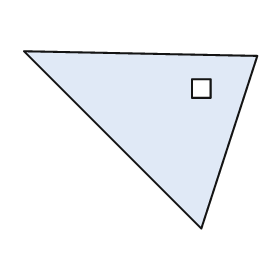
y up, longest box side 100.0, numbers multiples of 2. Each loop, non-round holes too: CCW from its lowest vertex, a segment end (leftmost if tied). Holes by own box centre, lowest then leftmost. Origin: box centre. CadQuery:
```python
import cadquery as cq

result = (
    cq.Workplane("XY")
    .moveTo(26.0, -38.0)
    .lineTo(50.0, 36.0)
    .lineTo(-50.0, 38.0)
    .close()
    .moveTo(22.0, 18.0)
    .lineTo(30.0, 18.0)
    .lineTo(30.0, 26.0)
    .lineTo(22.0, 26.0)
    .close()
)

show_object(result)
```